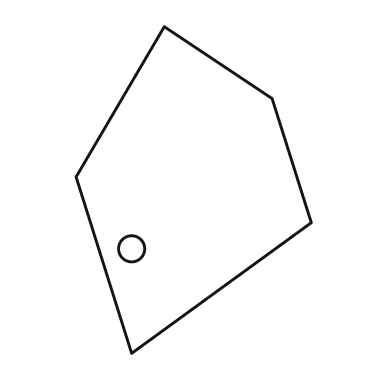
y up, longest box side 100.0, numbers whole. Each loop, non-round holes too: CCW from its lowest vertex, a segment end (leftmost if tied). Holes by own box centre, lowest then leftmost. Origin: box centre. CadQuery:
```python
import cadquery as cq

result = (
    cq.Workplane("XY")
    .moveTo(-19.0, -50.0)
    .lineTo(36.0, -10.0)
    .lineTo(24.0, 28.0)
    .lineTo(-9.0, 50.0)
    .lineTo(-36.0, 4.0)
    .close()
    .moveTo(-19.0, -18.0)
    .circle(4.0)
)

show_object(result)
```